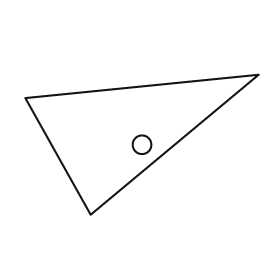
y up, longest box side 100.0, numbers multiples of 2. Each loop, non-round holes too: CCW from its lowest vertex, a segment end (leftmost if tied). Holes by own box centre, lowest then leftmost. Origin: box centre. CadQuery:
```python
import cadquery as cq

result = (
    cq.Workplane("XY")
    .moveTo(-22.0, -30.0)
    .lineTo(50.0, 30.0)
    .lineTo(-50.0, 20.0)
    .close()
    .moveTo(0.0, 0.0)
    .circle(4.0)
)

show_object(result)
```